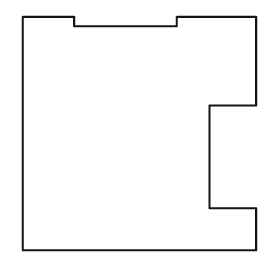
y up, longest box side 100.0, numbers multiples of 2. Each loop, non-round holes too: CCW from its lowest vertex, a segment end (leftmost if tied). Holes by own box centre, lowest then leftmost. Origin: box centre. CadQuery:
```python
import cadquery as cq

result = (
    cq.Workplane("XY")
    .moveTo(-50.0, -50.0)
    .lineTo(50.0, -50.0)
    .lineTo(50.0, -32.0)
    .lineTo(30.0, -32.0)
    .lineTo(30.0, 12.0)
    .lineTo(50.0, 12.0)
    .lineTo(50.0, 50.0)
    .lineTo(16.0, 50.0)
    .lineTo(16.0, 46.0)
    .lineTo(-28.0, 46.0)
    .lineTo(-28.0, 50.0)
    .lineTo(-50.0, 50.0)
    .close()
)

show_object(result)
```